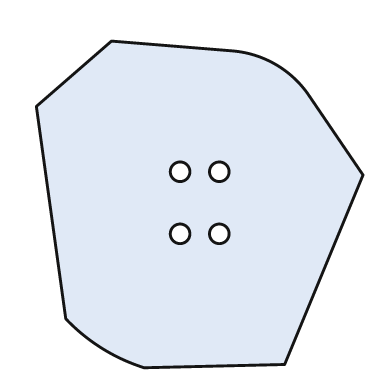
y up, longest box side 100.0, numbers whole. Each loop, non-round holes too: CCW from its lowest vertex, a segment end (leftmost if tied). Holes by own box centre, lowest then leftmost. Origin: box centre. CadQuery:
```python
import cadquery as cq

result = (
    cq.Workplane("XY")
    .moveTo(-17.0, -50.0)
    .lineTo(26.0, -49.0)
    .lineTo(50.0, 9.0)
    .lineTo(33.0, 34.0)
    .threePointArc((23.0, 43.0), (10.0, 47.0))
    .lineTo(-27.0, 50.0)
    .lineTo(-50.0, 30.0)
    .lineTo(-41.0, -35.0)
    .threePointArc((-30.0, -44.0), (-17.0, -50.0))
    .close()
    .moveTo(-6.0, -9.0)
    .circle(3.0)
    .moveTo(6.0, -9.0)
    .circle(3.0)
    .moveTo(-6.0, 10.0)
    .circle(3.0)
    .moveTo(6.0, 10.0)
    .circle(3.0)
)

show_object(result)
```